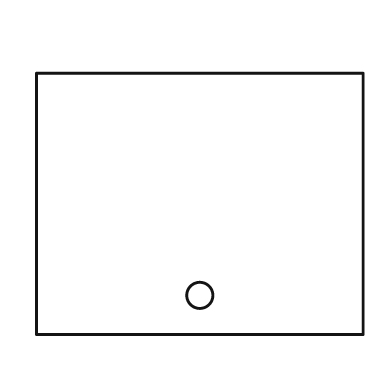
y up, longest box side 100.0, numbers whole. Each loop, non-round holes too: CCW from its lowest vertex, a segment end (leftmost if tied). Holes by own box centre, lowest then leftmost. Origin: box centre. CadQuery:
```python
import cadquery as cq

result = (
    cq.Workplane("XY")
    .moveTo(-50.0, -40.0)
    .lineTo(50.0, -40.0)
    .lineTo(50.0, 40.0)
    .lineTo(-50.0, 40.0)
    .close()
    .moveTo(0.0, -28.0)
    .circle(4.0)
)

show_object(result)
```